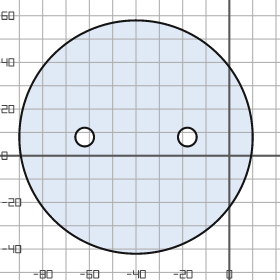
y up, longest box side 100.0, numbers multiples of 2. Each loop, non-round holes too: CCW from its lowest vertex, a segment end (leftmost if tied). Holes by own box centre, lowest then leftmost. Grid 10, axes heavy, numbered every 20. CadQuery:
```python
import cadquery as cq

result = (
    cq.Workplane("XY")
    .moveTo(-40.0, 8.0)
    .circle(50.0)
    .moveTo(-62.0, 8.0)
    .circle(4.0)
    .moveTo(-18.0, 8.0)
    .circle(4.0)
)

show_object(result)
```